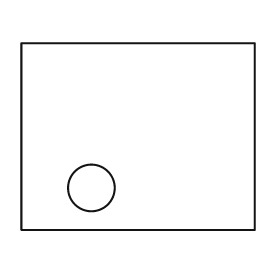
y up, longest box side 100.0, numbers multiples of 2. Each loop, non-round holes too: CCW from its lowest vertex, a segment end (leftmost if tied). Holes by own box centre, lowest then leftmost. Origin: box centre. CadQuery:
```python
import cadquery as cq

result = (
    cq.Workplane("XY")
    .moveTo(-50.0, -40.0)
    .lineTo(50.0, -40.0)
    .lineTo(50.0, 40.0)
    .lineTo(-50.0, 40.0)
    .close()
    .moveTo(-20.0, -22.0)
    .circle(10.0)
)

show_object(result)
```